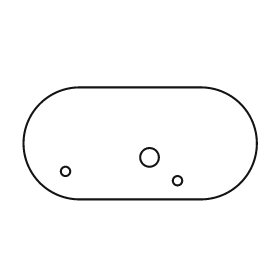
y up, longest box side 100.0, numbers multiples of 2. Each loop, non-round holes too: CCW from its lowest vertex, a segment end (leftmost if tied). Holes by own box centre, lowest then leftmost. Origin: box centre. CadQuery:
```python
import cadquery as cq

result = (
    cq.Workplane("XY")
    .moveTo(-26.0, -24.0)
    .lineTo(26.0, -24.0)
    .threePointArc((50.0, 0.0), (26.0, 24.0))
    .lineTo(-26.0, 24.0)
    .threePointArc((-50.0, 0.0), (-26.0, -24.0))
    .close()
    .moveTo(16.0, -16.0)
    .circle(2.0)
    .moveTo(-32.0, -12.0)
    .circle(2.0)
    .moveTo(4.0, -6.0)
    .circle(4.0)
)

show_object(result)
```